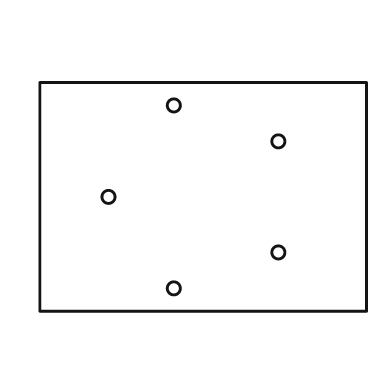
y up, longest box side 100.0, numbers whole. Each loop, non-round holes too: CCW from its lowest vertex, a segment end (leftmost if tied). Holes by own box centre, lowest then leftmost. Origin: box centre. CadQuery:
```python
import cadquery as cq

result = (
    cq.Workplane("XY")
    .moveTo(-50.0, -35.0)
    .lineTo(50.0, -35.0)
    .lineTo(50.0, 35.0)
    .lineTo(-50.0, 35.0)
    .close()
    .moveTo(-9.0, -28.0)
    .circle(2.0)
    .moveTo(23.0, -17.0)
    .circle(2.0)
    .moveTo(-29.0, 0.0)
    .circle(2.0)
    .moveTo(23.0, 17.0)
    .circle(2.0)
    .moveTo(-9.0, 28.0)
    .circle(2.0)
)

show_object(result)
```